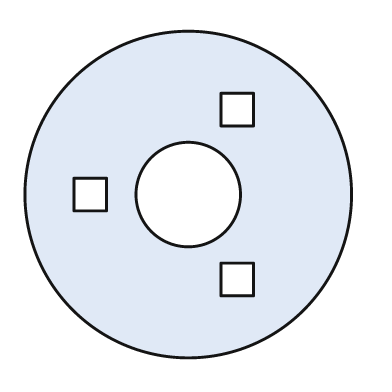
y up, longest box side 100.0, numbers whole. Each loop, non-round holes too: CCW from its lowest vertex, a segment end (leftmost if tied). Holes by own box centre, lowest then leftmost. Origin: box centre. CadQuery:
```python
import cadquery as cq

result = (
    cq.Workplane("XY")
    .moveTo(0.0, 0.0)
    .circle(50.0)
    .moveTo(10.0, -31.0)
    .lineTo(20.0, -31.0)
    .lineTo(20.0, -21.0)
    .lineTo(10.0, -21.0)
    .close()
    .moveTo(-35.0, -5.0)
    .lineTo(-25.0, -5.0)
    .lineTo(-25.0, 5.0)
    .lineTo(-35.0, 5.0)
    .close()
    .moveTo(0.0, 0.0)
    .circle(16.0)
    .moveTo(10.0, 21.0)
    .lineTo(20.0, 21.0)
    .lineTo(20.0, 31.0)
    .lineTo(10.0, 31.0)
    .close()
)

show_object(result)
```